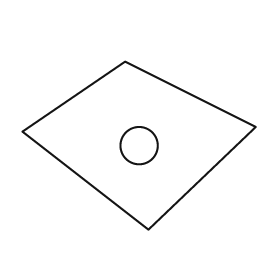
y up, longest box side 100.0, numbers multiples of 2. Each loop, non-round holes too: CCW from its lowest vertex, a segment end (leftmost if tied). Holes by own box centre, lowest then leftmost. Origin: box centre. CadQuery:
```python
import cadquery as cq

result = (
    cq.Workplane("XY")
    .moveTo(4.0, -36.0)
    .lineTo(50.0, 8.0)
    .lineTo(-6.0, 36.0)
    .lineTo(-50.0, 6.0)
    .close()
    .moveTo(0.0, 0.0)
    .circle(8.0)
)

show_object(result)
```